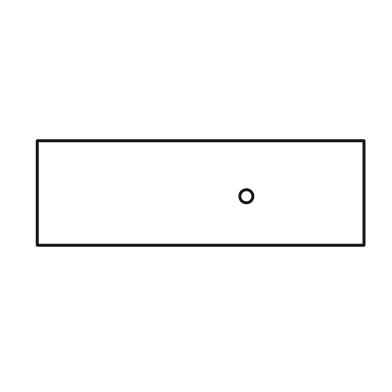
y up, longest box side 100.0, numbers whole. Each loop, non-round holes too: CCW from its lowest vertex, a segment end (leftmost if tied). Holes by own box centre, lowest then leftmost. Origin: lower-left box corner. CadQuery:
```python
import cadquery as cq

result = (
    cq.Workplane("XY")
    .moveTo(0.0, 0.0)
    .lineTo(100.0, 0.0)
    .lineTo(100.0, 32.0)
    .lineTo(0.0, 32.0)
    .close()
    .moveTo(64.0, 15.0)
    .circle(2.0)
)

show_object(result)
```